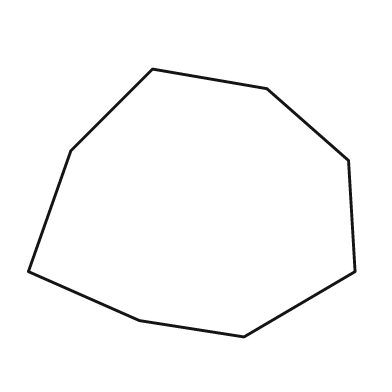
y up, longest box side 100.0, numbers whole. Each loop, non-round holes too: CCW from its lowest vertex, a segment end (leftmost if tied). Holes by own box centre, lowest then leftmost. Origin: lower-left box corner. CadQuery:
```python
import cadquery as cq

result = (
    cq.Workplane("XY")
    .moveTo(66.0, 0.0)
    .lineTo(100.0, 20.0)
    .lineTo(98.0, 54.0)
    .lineTo(73.0, 76.0)
    .lineTo(38.0, 82.0)
    .lineTo(13.0, 57.0)
    .lineTo(0.0, 20.0)
    .lineTo(34.0, 5.0)
    .close()
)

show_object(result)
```